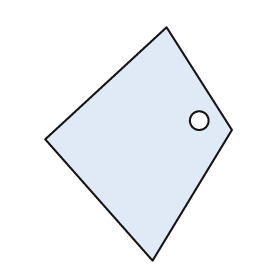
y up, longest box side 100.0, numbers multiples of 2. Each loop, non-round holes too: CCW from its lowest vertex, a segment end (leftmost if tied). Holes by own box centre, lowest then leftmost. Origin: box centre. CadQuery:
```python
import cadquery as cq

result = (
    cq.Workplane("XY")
    .moveTo(6.0, -50.0)
    .lineTo(40.0, 6.0)
    .lineTo(12.0, 50.0)
    .lineTo(-40.0, 2.0)
    .close()
    .moveTo(26.0, 10.0)
    .circle(4.0)
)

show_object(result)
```